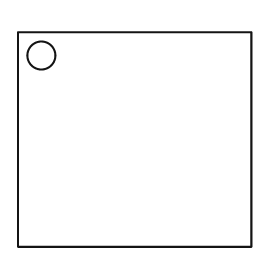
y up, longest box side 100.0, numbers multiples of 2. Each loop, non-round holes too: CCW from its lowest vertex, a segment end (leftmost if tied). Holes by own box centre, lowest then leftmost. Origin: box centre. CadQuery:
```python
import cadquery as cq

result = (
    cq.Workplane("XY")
    .moveTo(-50.0, -46.0)
    .lineTo(50.0, -46.0)
    .lineTo(50.0, 46.0)
    .lineTo(-50.0, 46.0)
    .close()
    .moveTo(-40.0, 36.0)
    .circle(6.0)
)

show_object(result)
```